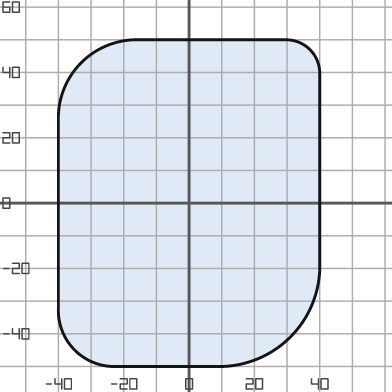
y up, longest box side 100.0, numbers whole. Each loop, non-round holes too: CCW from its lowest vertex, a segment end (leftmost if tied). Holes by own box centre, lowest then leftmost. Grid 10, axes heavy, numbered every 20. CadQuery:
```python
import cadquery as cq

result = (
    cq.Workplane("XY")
    .moveTo(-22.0, -50.0)
    .lineTo(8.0, -50.0)
    .threePointArc((31.0, -41.0), (40.0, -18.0))
    .lineTo(40.0, 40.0)
    .threePointArc((37.0, 47.0), (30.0, 50.0))
    .lineTo(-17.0, 50.0)
    .threePointArc((-33.0, 43.0), (-40.0, 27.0))
    .lineTo(-40.0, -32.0)
    .threePointArc((-35.0, -45.0), (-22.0, -50.0))
    .close()
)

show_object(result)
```